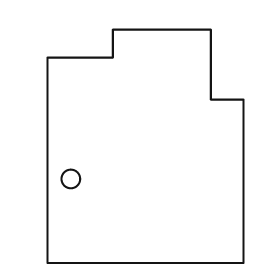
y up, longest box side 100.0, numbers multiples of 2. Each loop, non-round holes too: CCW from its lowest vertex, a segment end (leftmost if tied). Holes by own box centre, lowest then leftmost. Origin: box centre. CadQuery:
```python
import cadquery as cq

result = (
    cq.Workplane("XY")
    .moveTo(-42.0, -50.0)
    .lineTo(42.0, -50.0)
    .lineTo(42.0, 20.0)
    .lineTo(28.0, 20.0)
    .lineTo(28.0, 50.0)
    .lineTo(-14.0, 50.0)
    .lineTo(-14.0, 38.0)
    .lineTo(-42.0, 38.0)
    .close()
    .moveTo(-32.0, -14.0)
    .circle(4.0)
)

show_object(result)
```